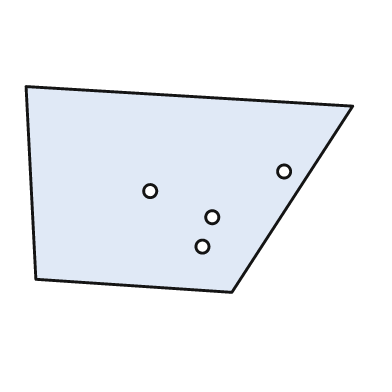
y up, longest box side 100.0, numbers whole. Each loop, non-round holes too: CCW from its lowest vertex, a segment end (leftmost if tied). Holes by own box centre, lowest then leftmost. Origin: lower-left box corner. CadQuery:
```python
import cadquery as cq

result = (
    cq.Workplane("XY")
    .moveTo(63.0, 0.0)
    .lineTo(100.0, 57.0)
    .lineTo(0.0, 63.0)
    .lineTo(3.0, 4.0)
    .close()
    .moveTo(54.0, 14.0)
    .circle(2.0)
    .moveTo(57.0, 23.0)
    .circle(2.0)
    .moveTo(38.0, 31.0)
    .circle(2.0)
    .moveTo(79.0, 37.0)
    .circle(2.0)
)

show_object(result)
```